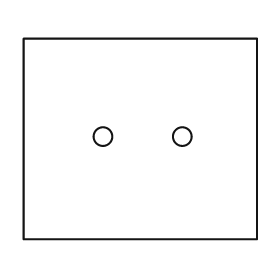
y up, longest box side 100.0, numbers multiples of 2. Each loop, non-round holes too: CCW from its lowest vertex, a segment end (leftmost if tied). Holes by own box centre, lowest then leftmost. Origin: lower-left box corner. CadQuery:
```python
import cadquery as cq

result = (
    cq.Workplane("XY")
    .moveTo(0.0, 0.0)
    .lineTo(100.0, 0.0)
    .lineTo(100.0, 86.0)
    .lineTo(0.0, 86.0)
    .close()
    .moveTo(34.0, 44.0)
    .circle(4.0)
    .moveTo(68.0, 44.0)
    .circle(4.0)
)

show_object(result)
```